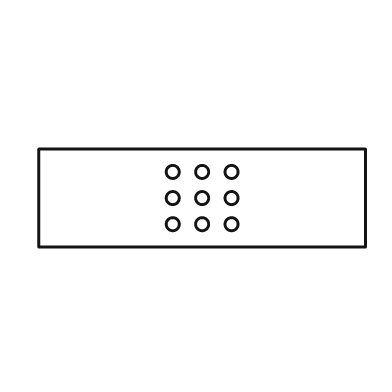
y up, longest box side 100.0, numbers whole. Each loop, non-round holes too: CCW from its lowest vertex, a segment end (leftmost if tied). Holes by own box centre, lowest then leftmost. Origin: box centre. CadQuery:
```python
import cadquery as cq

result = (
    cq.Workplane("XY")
    .moveTo(-50.0, -15.0)
    .lineTo(50.0, -15.0)
    .lineTo(50.0, 15.0)
    .lineTo(-50.0, 15.0)
    .close()
    .moveTo(-9.0, -8.0)
    .circle(2.0)
    .moveTo(0.0, -8.0)
    .circle(2.0)
    .moveTo(9.0, -8.0)
    .circle(2.0)
    .moveTo(-9.0, 0.0)
    .circle(2.0)
    .moveTo(0.0, 0.0)
    .circle(2.0)
    .moveTo(9.0, 0.0)
    .circle(2.0)
    .moveTo(-9.0, 8.0)
    .circle(2.0)
    .moveTo(0.0, 8.0)
    .circle(2.0)
    .moveTo(9.0, 8.0)
    .circle(2.0)
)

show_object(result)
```